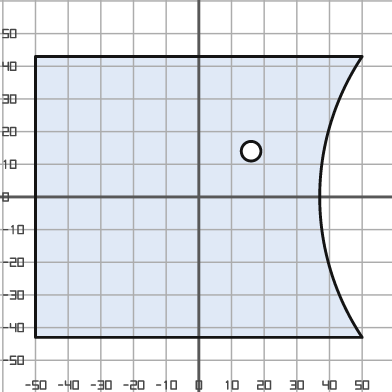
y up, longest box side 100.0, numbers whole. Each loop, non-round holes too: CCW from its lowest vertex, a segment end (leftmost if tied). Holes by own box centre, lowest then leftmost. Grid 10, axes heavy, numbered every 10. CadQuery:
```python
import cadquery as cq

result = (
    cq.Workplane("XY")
    .moveTo(-50.0, -43.0)
    .lineTo(50.0, -43.0)
    .threePointArc((37.0, 0.0), (50.0, 43.0))
    .lineTo(-50.0, 43.0)
    .close()
    .moveTo(16.0, 14.0)
    .circle(3.0)
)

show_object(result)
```